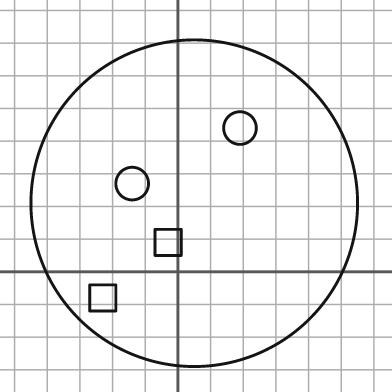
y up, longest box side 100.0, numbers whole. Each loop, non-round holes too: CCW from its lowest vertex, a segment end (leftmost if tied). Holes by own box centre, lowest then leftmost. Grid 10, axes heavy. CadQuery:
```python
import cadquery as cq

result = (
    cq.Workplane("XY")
    .moveTo(5.0, 21.0)
    .circle(50.0)
    .moveTo(-27.0, -12.0)
    .lineTo(-19.0, -12.0)
    .lineTo(-19.0, -4.0)
    .lineTo(-27.0, -4.0)
    .close()
    .moveTo(-7.0, 5.0)
    .lineTo(1.0, 5.0)
    .lineTo(1.0, 13.0)
    .lineTo(-7.0, 13.0)
    .close()
    .moveTo(-14.0, 27.0)
    .circle(5.0)
    .moveTo(19.0, 44.0)
    .circle(5.0)
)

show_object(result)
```